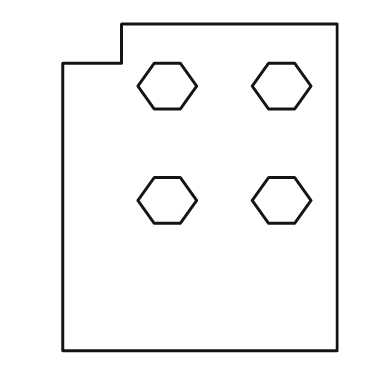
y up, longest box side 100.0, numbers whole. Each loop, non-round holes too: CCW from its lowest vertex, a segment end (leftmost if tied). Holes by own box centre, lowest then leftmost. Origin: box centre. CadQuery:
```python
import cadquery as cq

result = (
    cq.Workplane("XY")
    .moveTo(-42.0, -50.0)
    .lineTo(42.0, -50.0)
    .lineTo(42.0, 50.0)
    .lineTo(-24.0, 50.0)
    .lineTo(-24.0, 38.0)
    .lineTo(-42.0, 38.0)
    .close()
    .moveTo(-14.0, -11.0)
    .lineTo(-6.0, -11.0)
    .lineTo(-1.0, -4.0)
    .lineTo(-6.0, 3.0)
    .lineTo(-14.0, 3.0)
    .lineTo(-19.0, -4.0)
    .close()
    .moveTo(21.0, -11.0)
    .lineTo(29.0, -11.0)
    .lineTo(34.0, -4.0)
    .lineTo(29.0, 3.0)
    .lineTo(21.0, 3.0)
    .lineTo(16.0, -4.0)
    .close()
    .moveTo(-14.0, 24.0)
    .lineTo(-6.0, 24.0)
    .lineTo(-1.0, 31.0)
    .lineTo(-6.0, 38.0)
    .lineTo(-14.0, 38.0)
    .lineTo(-19.0, 31.0)
    .close()
    .moveTo(21.0, 24.0)
    .lineTo(29.0, 24.0)
    .lineTo(34.0, 31.0)
    .lineTo(29.0, 38.0)
    .lineTo(21.0, 38.0)
    .lineTo(16.0, 31.0)
    .close()
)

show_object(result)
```